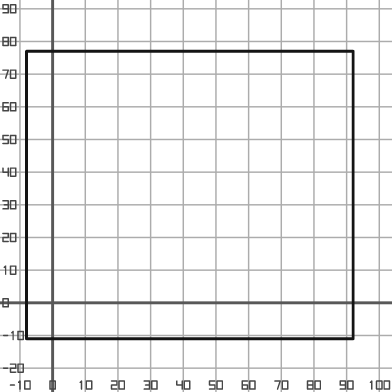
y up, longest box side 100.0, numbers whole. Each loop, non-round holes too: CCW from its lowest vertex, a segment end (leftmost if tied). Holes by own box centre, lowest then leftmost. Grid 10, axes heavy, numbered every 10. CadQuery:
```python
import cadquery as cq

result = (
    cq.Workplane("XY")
    .moveTo(-8.0, -11.0)
    .lineTo(92.0, -11.0)
    .lineTo(92.0, 77.0)
    .lineTo(-8.0, 77.0)
    .close()
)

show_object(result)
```